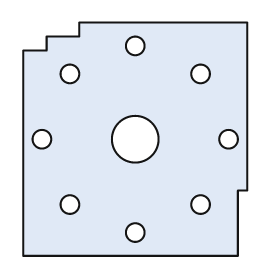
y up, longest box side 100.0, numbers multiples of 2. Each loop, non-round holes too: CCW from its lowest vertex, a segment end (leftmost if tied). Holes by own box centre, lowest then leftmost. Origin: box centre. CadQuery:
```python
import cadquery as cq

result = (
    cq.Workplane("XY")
    .moveTo(-48.0, -50.0)
    .lineTo(44.0, -50.0)
    .lineTo(44.0, -22.0)
    .lineTo(48.0, -22.0)
    .lineTo(48.0, 50.0)
    .lineTo(-24.0, 50.0)
    .lineTo(-24.0, 44.0)
    .lineTo(-38.0, 44.0)
    .lineTo(-38.0, 38.0)
    .lineTo(-48.0, 38.0)
    .close()
    .moveTo(0.0, -40.0)
    .circle(4.0)
    .moveTo(-28.0, -28.0)
    .circle(4.0)
    .moveTo(28.0, -28.0)
    .circle(4.0)
    .moveTo(-40.0, 0.0)
    .circle(4.0)
    .moveTo(0.0, 0.0)
    .circle(10.0)
    .moveTo(40.0, 0.0)
    .circle(4.0)
    .moveTo(-28.0, 28.0)
    .circle(4.0)
    .moveTo(28.0, 28.0)
    .circle(4.0)
    .moveTo(0.0, 40.0)
    .circle(4.0)
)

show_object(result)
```